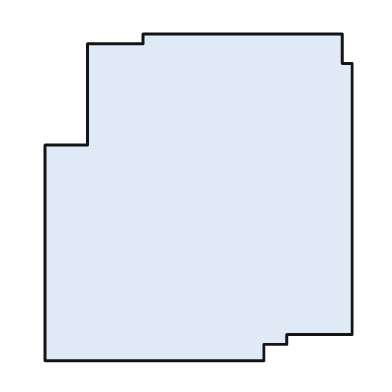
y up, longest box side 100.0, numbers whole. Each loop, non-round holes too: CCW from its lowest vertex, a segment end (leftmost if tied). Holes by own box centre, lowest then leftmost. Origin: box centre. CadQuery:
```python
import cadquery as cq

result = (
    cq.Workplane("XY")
    .moveTo(-47.0, -50.0)
    .lineTo(20.0, -50.0)
    .lineTo(20.0, -45.0)
    .lineTo(27.0, -45.0)
    .lineTo(27.0, -42.0)
    .lineTo(47.0, -42.0)
    .lineTo(47.0, 41.0)
    .lineTo(44.0, 41.0)
    .lineTo(44.0, 50.0)
    .lineTo(-17.0, 50.0)
    .lineTo(-17.0, 47.0)
    .lineTo(-34.0, 47.0)
    .lineTo(-34.0, 16.0)
    .lineTo(-47.0, 16.0)
    .close()
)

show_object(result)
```